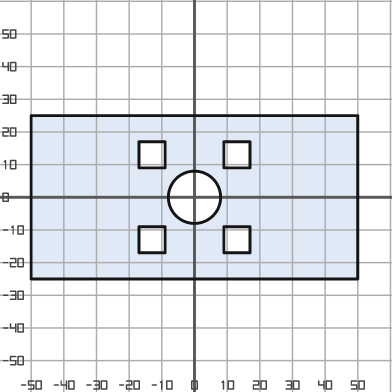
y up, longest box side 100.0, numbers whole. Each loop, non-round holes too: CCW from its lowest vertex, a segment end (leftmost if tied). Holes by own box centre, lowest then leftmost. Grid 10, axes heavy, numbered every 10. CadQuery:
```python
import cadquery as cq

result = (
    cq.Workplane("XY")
    .moveTo(-50.0, -25.0)
    .lineTo(50.0, -25.0)
    .lineTo(50.0, 25.0)
    .lineTo(-50.0, 25.0)
    .close()
    .moveTo(-17.0, -17.0)
    .lineTo(-9.0, -17.0)
    .lineTo(-9.0, -9.0)
    .lineTo(-17.0, -9.0)
    .close()
    .moveTo(9.0, -17.0)
    .lineTo(17.0, -17.0)
    .lineTo(17.0, -9.0)
    .lineTo(9.0, -9.0)
    .close()
    .moveTo(0.0, 0.0)
    .circle(8.0)
    .moveTo(-17.0, 9.0)
    .lineTo(-9.0, 9.0)
    .lineTo(-9.0, 17.0)
    .lineTo(-17.0, 17.0)
    .close()
    .moveTo(9.0, 9.0)
    .lineTo(17.0, 9.0)
    .lineTo(17.0, 17.0)
    .lineTo(9.0, 17.0)
    .close()
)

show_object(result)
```